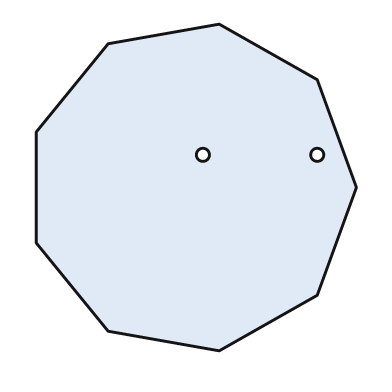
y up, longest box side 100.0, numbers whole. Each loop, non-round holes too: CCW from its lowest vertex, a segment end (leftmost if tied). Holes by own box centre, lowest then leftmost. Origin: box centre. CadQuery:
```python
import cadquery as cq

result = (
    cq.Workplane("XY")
    .moveTo(7.0, -50.0)
    .lineTo(37.0, -33.0)
    .lineTo(49.0, 0.0)
    .lineTo(37.0, 33.0)
    .lineTo(7.0, 50.0)
    .lineTo(-27.0, 44.0)
    .lineTo(-49.0, 17.0)
    .lineTo(-49.0, -17.0)
    .lineTo(-27.0, -44.0)
    .close()
    .moveTo(2.0, 10.0)
    .circle(2.0)
    .moveTo(37.0, 10.0)
    .circle(2.0)
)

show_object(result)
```